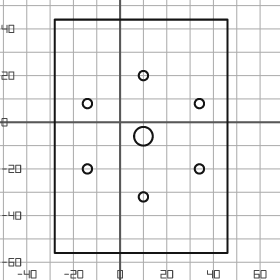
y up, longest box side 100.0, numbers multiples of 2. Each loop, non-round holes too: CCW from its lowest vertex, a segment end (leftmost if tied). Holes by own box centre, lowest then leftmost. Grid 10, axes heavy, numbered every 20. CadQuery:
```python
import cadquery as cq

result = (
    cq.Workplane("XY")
    .moveTo(-28.0, -56.0)
    .lineTo(46.0, -56.0)
    .lineTo(46.0, 44.0)
    .lineTo(-28.0, 44.0)
    .close()
    .moveTo(10.0, -32.0)
    .circle(2.0)
    .moveTo(-14.0, -20.0)
    .circle(2.0)
    .moveTo(34.0, -20.0)
    .circle(2.0)
    .moveTo(10.0, -6.0)
    .circle(4.0)
    .moveTo(-14.0, 8.0)
    .circle(2.0)
    .moveTo(34.0, 8.0)
    .circle(2.0)
    .moveTo(10.0, 20.0)
    .circle(2.0)
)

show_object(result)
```